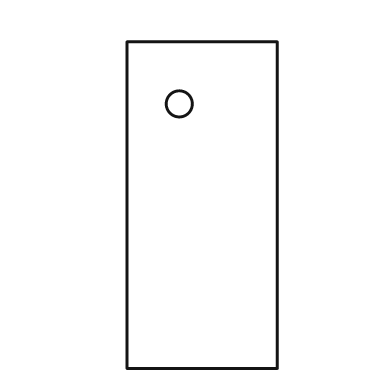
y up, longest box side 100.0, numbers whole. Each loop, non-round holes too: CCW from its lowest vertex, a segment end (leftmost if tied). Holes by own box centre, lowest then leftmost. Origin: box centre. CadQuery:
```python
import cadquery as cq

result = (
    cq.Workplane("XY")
    .moveTo(-23.0, -50.0)
    .lineTo(23.0, -50.0)
    .lineTo(23.0, 50.0)
    .lineTo(-23.0, 50.0)
    .close()
    .moveTo(-7.0, 31.0)
    .circle(4.0)
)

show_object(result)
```